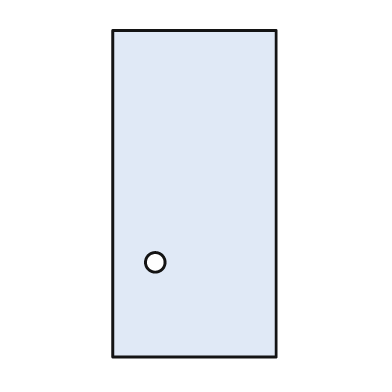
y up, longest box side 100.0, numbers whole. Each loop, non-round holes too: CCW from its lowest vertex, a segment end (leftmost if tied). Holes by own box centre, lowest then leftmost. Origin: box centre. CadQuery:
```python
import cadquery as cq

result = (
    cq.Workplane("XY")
    .moveTo(-25.0, -50.0)
    .lineTo(25.0, -50.0)
    .lineTo(25.0, 50.0)
    .lineTo(-25.0, 50.0)
    .close()
    .moveTo(-12.0, -21.0)
    .circle(3.0)
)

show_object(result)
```